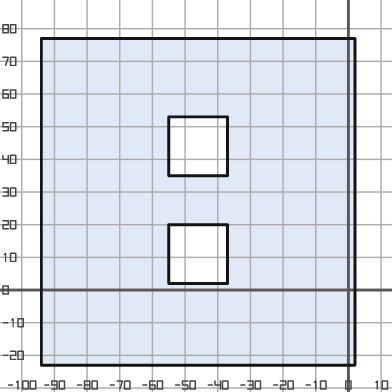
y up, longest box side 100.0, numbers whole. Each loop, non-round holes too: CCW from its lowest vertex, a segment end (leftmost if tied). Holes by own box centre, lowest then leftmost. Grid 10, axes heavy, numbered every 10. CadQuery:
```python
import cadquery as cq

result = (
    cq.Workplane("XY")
    .moveTo(-94.0, -23.0)
    .lineTo(2.0, -23.0)
    .lineTo(2.0, 77.0)
    .lineTo(-94.0, 77.0)
    .close()
    .moveTo(-55.0, 2.0)
    .lineTo(-37.0, 2.0)
    .lineTo(-37.0, 20.0)
    .lineTo(-55.0, 20.0)
    .close()
    .moveTo(-55.0, 35.0)
    .lineTo(-37.0, 35.0)
    .lineTo(-37.0, 53.0)
    .lineTo(-55.0, 53.0)
    .close()
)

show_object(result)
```